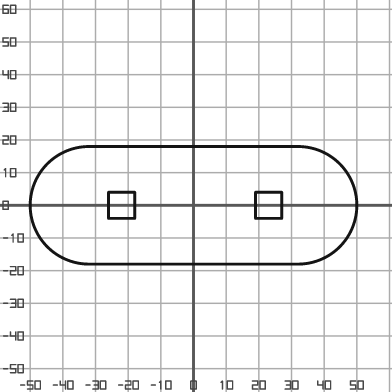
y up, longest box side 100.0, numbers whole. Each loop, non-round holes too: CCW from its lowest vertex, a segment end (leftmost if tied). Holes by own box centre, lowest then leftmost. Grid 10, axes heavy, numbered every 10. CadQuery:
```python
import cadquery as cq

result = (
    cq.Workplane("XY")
    .moveTo(-32.0, -18.0)
    .lineTo(32.0, -18.0)
    .threePointArc((50.0, 0.0), (32.0, 18.0))
    .lineTo(-32.0, 18.0)
    .threePointArc((-50.0, 0.0), (-32.0, -18.0))
    .close()
    .moveTo(-26.0, -4.0)
    .lineTo(-18.0, -4.0)
    .lineTo(-18.0, 4.0)
    .lineTo(-26.0, 4.0)
    .close()
    .moveTo(19.0, -4.0)
    .lineTo(27.0, -4.0)
    .lineTo(27.0, 4.0)
    .lineTo(19.0, 4.0)
    .close()
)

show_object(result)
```